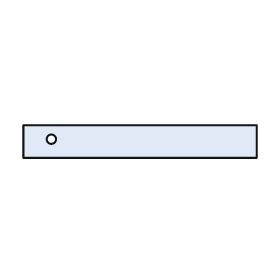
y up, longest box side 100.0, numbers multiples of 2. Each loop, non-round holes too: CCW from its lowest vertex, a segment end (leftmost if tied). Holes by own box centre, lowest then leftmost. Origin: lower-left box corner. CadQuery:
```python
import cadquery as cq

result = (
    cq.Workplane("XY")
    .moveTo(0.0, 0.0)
    .lineTo(100.0, 0.0)
    .lineTo(100.0, 14.0)
    .lineTo(0.0, 14.0)
    .close()
    .moveTo(12.0, 8.0)
    .circle(2.0)
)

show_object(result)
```